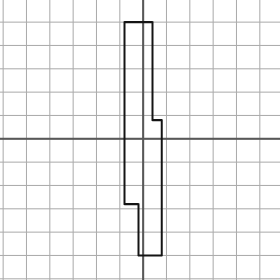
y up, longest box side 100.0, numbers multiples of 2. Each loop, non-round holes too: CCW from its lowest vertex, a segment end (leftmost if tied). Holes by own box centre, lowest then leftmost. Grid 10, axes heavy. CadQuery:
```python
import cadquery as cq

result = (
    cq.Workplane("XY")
    .moveTo(-2.0, -50.0)
    .lineTo(8.0, -50.0)
    .lineTo(8.0, 8.0)
    .lineTo(4.0, 8.0)
    .lineTo(4.0, 50.0)
    .lineTo(-8.0, 50.0)
    .lineTo(-8.0, -28.0)
    .lineTo(-2.0, -28.0)
    .close()
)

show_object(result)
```